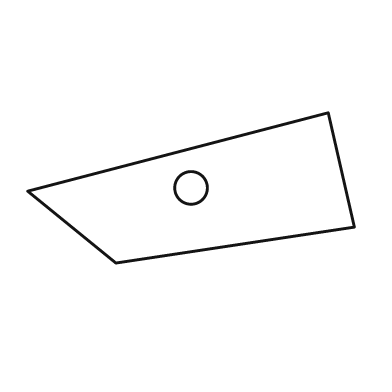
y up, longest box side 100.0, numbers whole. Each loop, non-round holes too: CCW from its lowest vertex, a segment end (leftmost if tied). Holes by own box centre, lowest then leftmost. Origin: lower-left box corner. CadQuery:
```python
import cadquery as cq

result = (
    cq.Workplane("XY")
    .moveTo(27.0, 0.0)
    .lineTo(100.0, 11.0)
    .lineTo(92.0, 46.0)
    .lineTo(0.0, 22.0)
    .close()
    .moveTo(50.0, 23.0)
    .circle(5.0)
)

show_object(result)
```